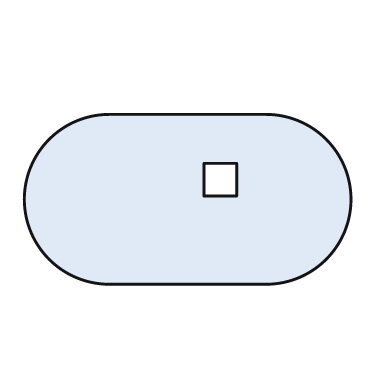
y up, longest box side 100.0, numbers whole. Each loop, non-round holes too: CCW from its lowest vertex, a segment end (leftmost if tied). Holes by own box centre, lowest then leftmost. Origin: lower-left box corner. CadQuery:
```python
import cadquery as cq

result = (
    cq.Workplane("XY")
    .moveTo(26.0, 0.0)
    .lineTo(74.0, 0.0)
    .threePointArc((100.0, 26.0), (74.0, 52.0))
    .lineTo(26.0, 52.0)
    .threePointArc((0.0, 26.0), (26.0, 0.0))
    .close()
    .moveTo(55.0, 27.0)
    .lineTo(65.0, 27.0)
    .lineTo(65.0, 37.0)
    .lineTo(55.0, 37.0)
    .close()
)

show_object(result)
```